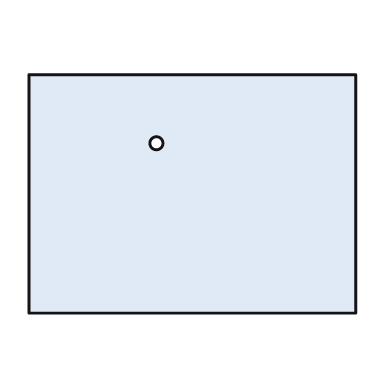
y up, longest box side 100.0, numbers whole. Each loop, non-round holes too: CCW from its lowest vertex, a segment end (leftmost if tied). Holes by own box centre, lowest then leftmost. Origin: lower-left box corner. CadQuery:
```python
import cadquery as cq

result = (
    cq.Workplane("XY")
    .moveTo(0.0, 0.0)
    .lineTo(100.0, 0.0)
    .lineTo(100.0, 73.0)
    .lineTo(0.0, 73.0)
    .close()
    .moveTo(39.0, 52.0)
    .circle(2.0)
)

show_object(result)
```